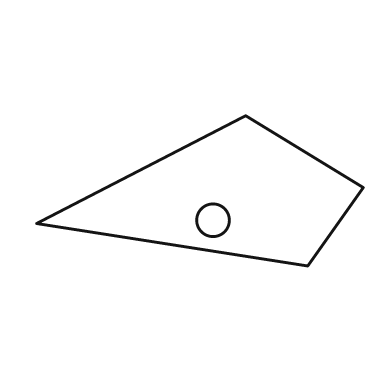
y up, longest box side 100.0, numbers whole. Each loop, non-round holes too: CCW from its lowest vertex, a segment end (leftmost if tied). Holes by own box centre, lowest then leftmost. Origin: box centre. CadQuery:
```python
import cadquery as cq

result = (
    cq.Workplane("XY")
    .moveTo(33.0, -23.0)
    .lineTo(50.0, 1.0)
    .lineTo(14.0, 23.0)
    .lineTo(-50.0, -10.0)
    .close()
    .moveTo(4.0, -9.0)
    .circle(5.0)
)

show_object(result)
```